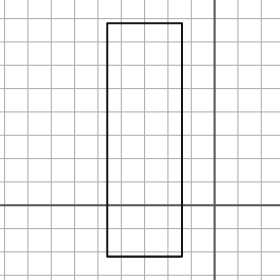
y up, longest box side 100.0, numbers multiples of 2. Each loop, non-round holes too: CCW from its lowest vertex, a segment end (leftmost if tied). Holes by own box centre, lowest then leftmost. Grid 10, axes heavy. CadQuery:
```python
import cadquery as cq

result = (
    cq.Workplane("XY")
    .moveTo(-46.0, -22.0)
    .lineTo(-14.0, -22.0)
    .lineTo(-14.0, 78.0)
    .lineTo(-46.0, 78.0)
    .close()
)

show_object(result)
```